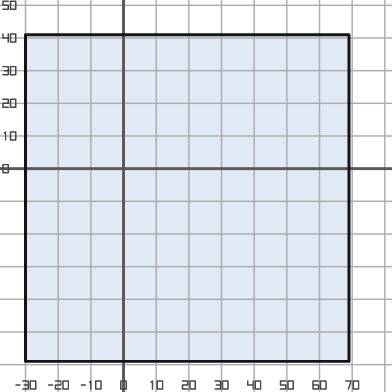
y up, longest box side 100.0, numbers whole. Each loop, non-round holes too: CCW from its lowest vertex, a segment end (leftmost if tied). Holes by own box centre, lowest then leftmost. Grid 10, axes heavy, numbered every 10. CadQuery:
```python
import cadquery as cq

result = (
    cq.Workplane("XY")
    .moveTo(-30.0, -59.0)
    .lineTo(69.0, -59.0)
    .lineTo(69.0, 41.0)
    .lineTo(-30.0, 41.0)
    .close()
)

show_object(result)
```